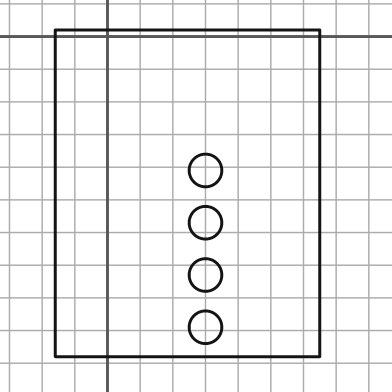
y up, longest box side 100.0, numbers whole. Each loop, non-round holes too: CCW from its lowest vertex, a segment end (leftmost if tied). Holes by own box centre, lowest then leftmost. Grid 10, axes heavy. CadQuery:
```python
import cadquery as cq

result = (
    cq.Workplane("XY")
    .moveTo(-16.0, -98.0)
    .lineTo(65.0, -98.0)
    .lineTo(65.0, 2.0)
    .lineTo(-16.0, 2.0)
    .close()
    .moveTo(30.0, -89.0)
    .circle(5.0)
    .moveTo(30.0, -73.0)
    .circle(5.0)
    .moveTo(30.0, -57.0)
    .circle(5.0)
    .moveTo(30.0, -41.0)
    .circle(5.0)
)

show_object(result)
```